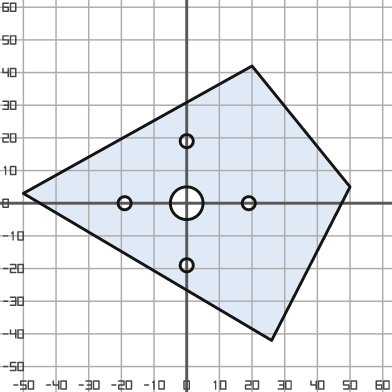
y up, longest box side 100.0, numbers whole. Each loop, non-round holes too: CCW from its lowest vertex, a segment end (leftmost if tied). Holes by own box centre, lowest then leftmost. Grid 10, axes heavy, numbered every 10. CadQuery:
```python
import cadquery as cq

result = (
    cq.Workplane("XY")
    .moveTo(26.0, -42.0)
    .lineTo(50.0, 5.0)
    .lineTo(20.0, 42.0)
    .lineTo(-50.0, 3.0)
    .close()
    .moveTo(0.0, -19.0)
    .circle(2.0)
    .moveTo(-19.0, 0.0)
    .circle(2.0)
    .moveTo(0.0, 0.0)
    .circle(5.0)
    .moveTo(19.0, 0.0)
    .circle(2.0)
    .moveTo(0.0, 19.0)
    .circle(2.0)
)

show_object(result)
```